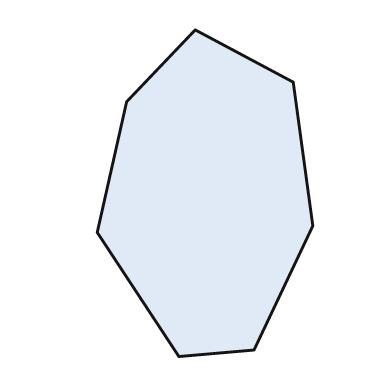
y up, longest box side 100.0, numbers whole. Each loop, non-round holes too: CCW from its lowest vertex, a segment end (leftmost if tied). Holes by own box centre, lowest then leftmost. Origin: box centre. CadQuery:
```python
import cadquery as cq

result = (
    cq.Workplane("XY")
    .moveTo(-8.0, -50.0)
    .lineTo(15.0, -48.0)
    .lineTo(33.0, -10.0)
    .lineTo(27.0, 34.0)
    .lineTo(-3.0, 50.0)
    .lineTo(-24.0, 28.0)
    .lineTo(-33.0, -12.0)
    .close()
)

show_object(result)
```